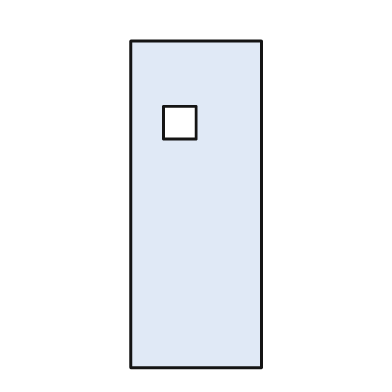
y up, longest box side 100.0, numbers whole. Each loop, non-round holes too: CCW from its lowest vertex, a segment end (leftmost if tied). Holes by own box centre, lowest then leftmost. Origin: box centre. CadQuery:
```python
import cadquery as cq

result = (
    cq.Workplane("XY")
    .moveTo(-20.0, -50.0)
    .lineTo(20.0, -50.0)
    .lineTo(20.0, 50.0)
    .lineTo(-20.0, 50.0)
    .close()
    .moveTo(-10.0, 20.0)
    .lineTo(0.0, 20.0)
    .lineTo(0.0, 30.0)
    .lineTo(-10.0, 30.0)
    .close()
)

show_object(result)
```